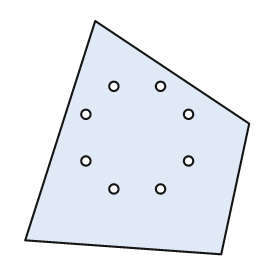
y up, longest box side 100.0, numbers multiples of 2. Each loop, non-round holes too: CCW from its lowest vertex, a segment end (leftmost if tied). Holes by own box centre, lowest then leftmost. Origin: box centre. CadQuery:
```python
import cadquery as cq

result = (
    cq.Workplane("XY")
    .moveTo(36.0, -50.0)
    .lineTo(48.0, 6.0)
    .lineTo(-18.0, 50.0)
    .lineTo(-48.0, -44.0)
    .close()
    .moveTo(-10.0, -22.0)
    .circle(2.0)
    .moveTo(10.0, -22.0)
    .circle(2.0)
    .moveTo(-22.0, -10.0)
    .circle(2.0)
    .moveTo(22.0, -10.0)
    .circle(2.0)
    .moveTo(-22.0, 10.0)
    .circle(2.0)
    .moveTo(22.0, 10.0)
    .circle(2.0)
    .moveTo(-10.0, 22.0)
    .circle(2.0)
    .moveTo(10.0, 22.0)
    .circle(2.0)
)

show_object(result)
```